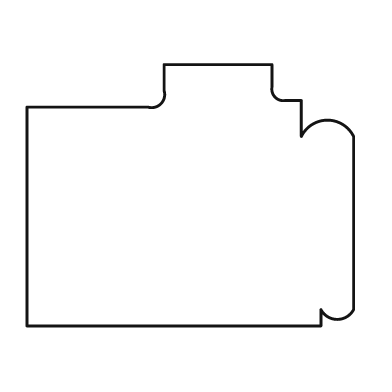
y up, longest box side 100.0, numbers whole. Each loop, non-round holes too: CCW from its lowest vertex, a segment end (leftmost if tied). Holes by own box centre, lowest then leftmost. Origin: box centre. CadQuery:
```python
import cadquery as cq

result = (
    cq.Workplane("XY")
    .moveTo(-50.0, -40.0)
    .lineTo(40.0, -40.0)
    .lineTo(40.0, -35.0)
    .threePointArc((45.0, -38.0), (50.0, -35.0))
    .lineTo(50.0, 18.0)
    .threePointArc((42.0, 23.0), (34.0, 18.0))
    .lineTo(34.0, 29.0)
    .lineTo(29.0, 29.0)
    .threePointArc((26.0, 30.0), (25.0, 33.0))
    .lineTo(25.0, 40.0)
    .lineTo(-8.0, 40.0)
    .lineTo(-8.0, 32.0)
    .threePointArc((-9.0, 28.0), (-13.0, 27.0))
    .lineTo(-50.0, 27.0)
    .close()
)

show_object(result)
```